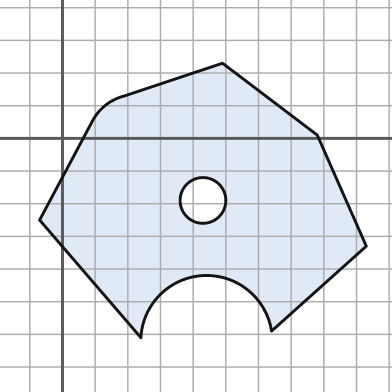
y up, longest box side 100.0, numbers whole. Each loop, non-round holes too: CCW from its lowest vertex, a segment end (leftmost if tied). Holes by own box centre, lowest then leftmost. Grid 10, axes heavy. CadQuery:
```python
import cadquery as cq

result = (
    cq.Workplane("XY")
    .moveTo(24.0, -61.0)
    .threePointArc((43.0, -42.0), (64.0, -59.0))
    .lineTo(93.0, -33.0)
    .lineTo(78.0, 1.0)
    .lineTo(49.0, 23.0)
    .lineTo(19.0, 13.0)
    .threePointArc((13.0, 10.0), (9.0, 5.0))
    .lineTo(-7.0, -25.0)
    .close()
    .moveTo(43.0, -19.0)
    .circle(7.0)
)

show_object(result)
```